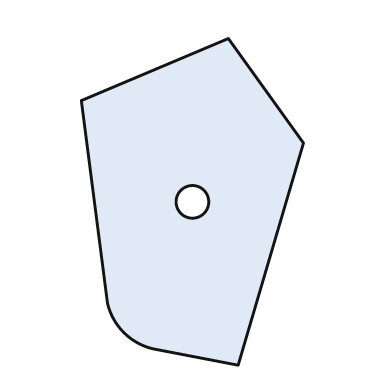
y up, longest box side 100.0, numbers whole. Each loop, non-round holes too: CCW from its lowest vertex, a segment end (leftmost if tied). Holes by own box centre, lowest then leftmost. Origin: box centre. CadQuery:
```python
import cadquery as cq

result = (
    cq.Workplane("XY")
    .moveTo(14.0, -50.0)
    .lineTo(34.0, 18.0)
    .lineTo(11.0, 50.0)
    .lineTo(-34.0, 31.0)
    .lineTo(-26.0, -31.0)
    .threePointArc((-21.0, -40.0), (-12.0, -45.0))
    .close()
    .moveTo(0.0, 0.0)
    .circle(5.0)
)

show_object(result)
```